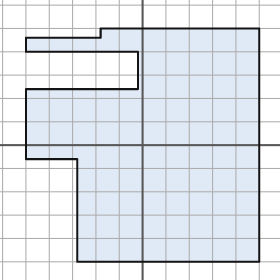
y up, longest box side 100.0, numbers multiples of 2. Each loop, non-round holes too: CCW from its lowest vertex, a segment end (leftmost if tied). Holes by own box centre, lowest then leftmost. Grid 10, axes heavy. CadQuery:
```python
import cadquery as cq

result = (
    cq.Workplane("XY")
    .moveTo(-28.0, -50.0)
    .lineTo(50.0, -50.0)
    .lineTo(50.0, 50.0)
    .lineTo(-18.0, 50.0)
    .lineTo(-18.0, 46.0)
    .lineTo(-50.0, 46.0)
    .lineTo(-50.0, 40.0)
    .lineTo(-2.0, 40.0)
    .lineTo(-2.0, 24.0)
    .lineTo(-50.0, 24.0)
    .lineTo(-50.0, -6.0)
    .lineTo(-28.0, -6.0)
    .close()
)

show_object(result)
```